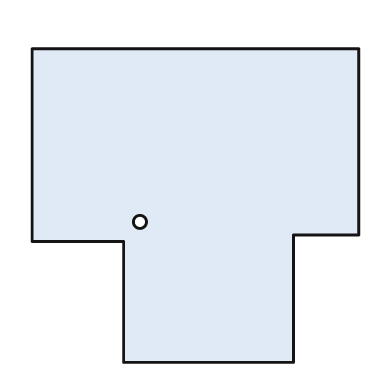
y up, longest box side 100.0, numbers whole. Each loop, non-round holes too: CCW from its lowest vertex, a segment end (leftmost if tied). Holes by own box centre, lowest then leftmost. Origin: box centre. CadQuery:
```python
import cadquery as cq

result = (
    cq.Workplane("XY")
    .moveTo(-22.0, -48.0)
    .lineTo(30.0, -48.0)
    .lineTo(30.0, -9.0)
    .lineTo(50.0, -9.0)
    .lineTo(50.0, 48.0)
    .lineTo(-50.0, 48.0)
    .lineTo(-50.0, -11.0)
    .lineTo(-22.0, -11.0)
    .close()
    .moveTo(-17.0, -5.0)
    .circle(2.0)
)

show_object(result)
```